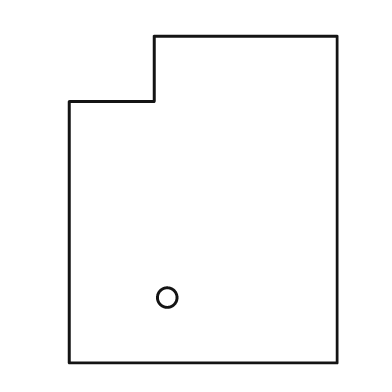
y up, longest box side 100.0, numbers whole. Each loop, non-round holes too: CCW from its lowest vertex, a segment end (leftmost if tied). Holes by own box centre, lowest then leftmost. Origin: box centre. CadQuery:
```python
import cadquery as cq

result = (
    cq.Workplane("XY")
    .moveTo(-41.0, -50.0)
    .lineTo(41.0, -50.0)
    .lineTo(41.0, 50.0)
    .lineTo(-15.0, 50.0)
    .lineTo(-15.0, 30.0)
    .lineTo(-41.0, 30.0)
    .close()
    .moveTo(-11.0, -30.0)
    .circle(3.0)
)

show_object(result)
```